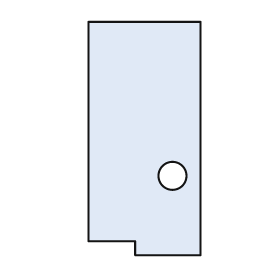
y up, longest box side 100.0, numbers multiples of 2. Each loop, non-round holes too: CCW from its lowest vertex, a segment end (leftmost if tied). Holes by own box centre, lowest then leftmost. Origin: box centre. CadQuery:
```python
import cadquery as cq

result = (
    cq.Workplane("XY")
    .moveTo(-4.0, -50.0)
    .lineTo(24.0, -50.0)
    .lineTo(24.0, 50.0)
    .lineTo(-24.0, 50.0)
    .lineTo(-24.0, -44.0)
    .lineTo(-4.0, -44.0)
    .close()
    .moveTo(12.0, -16.0)
    .circle(6.0)
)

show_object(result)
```